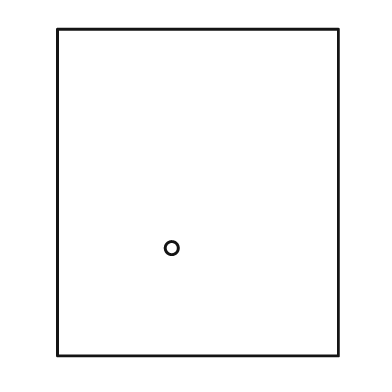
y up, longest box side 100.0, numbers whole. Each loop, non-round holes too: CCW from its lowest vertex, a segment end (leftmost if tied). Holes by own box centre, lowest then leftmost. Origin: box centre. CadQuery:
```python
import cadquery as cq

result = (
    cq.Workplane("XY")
    .moveTo(-43.0, -50.0)
    .lineTo(43.0, -50.0)
    .lineTo(43.0, 50.0)
    .lineTo(-43.0, 50.0)
    .close()
    .moveTo(-8.0, -17.0)
    .circle(2.0)
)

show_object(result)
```